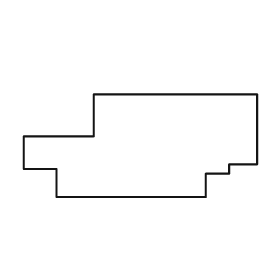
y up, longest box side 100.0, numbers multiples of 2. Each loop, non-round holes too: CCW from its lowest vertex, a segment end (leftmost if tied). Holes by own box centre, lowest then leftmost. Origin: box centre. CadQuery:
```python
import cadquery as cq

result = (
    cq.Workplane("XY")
    .moveTo(-36.0, -22.0)
    .lineTo(28.0, -22.0)
    .lineTo(28.0, -12.0)
    .lineTo(38.0, -12.0)
    .lineTo(38.0, -8.0)
    .lineTo(50.0, -8.0)
    .lineTo(50.0, 22.0)
    .lineTo(-20.0, 22.0)
    .lineTo(-20.0, 4.0)
    .lineTo(-50.0, 4.0)
    .lineTo(-50.0, -10.0)
    .lineTo(-36.0, -10.0)
    .close()
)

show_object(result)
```